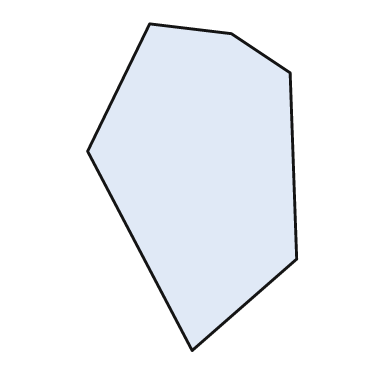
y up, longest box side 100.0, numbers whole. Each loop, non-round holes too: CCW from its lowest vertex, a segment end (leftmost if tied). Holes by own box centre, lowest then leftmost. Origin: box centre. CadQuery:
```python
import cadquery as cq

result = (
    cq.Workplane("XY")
    .moveTo(0.0, -50.0)
    .lineTo(32.0, -22.0)
    .lineTo(30.0, 35.0)
    .lineTo(12.0, 47.0)
    .lineTo(-13.0, 50.0)
    .lineTo(-32.0, 11.0)
    .close()
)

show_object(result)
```